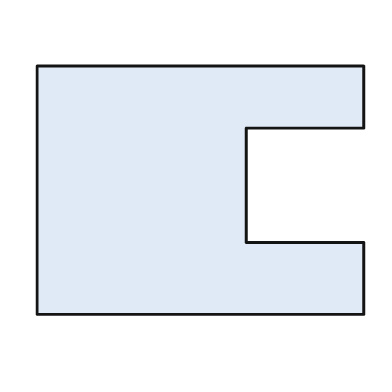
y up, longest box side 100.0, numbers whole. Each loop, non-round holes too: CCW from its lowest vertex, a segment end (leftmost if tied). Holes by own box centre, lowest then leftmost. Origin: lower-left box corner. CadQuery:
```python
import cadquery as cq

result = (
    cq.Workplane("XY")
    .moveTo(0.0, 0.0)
    .lineTo(100.0, 0.0)
    .lineTo(100.0, 22.0)
    .lineTo(64.0, 22.0)
    .lineTo(64.0, 57.0)
    .lineTo(100.0, 57.0)
    .lineTo(100.0, 76.0)
    .lineTo(0.0, 76.0)
    .close()
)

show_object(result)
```